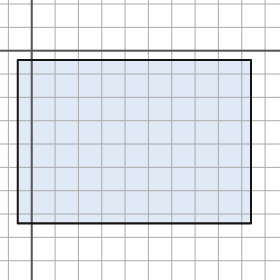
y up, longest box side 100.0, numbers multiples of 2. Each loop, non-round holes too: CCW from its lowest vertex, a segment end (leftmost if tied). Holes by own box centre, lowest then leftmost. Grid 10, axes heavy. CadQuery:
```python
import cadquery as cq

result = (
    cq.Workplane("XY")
    .moveTo(-6.0, -74.0)
    .lineTo(94.0, -74.0)
    .lineTo(94.0, -4.0)
    .lineTo(-6.0, -4.0)
    .close()
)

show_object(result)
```